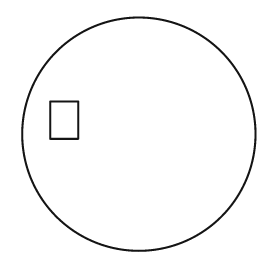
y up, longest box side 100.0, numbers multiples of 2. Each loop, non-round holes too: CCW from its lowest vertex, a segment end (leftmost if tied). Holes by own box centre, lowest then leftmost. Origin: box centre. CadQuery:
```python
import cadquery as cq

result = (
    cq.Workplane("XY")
    .moveTo(0.0, 0.0)
    .circle(50.0)
    .moveTo(-38.0, -2.0)
    .lineTo(-26.0, -2.0)
    .lineTo(-26.0, 14.0)
    .lineTo(-38.0, 14.0)
    .close()
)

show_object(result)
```